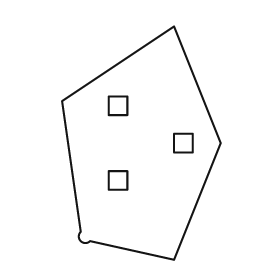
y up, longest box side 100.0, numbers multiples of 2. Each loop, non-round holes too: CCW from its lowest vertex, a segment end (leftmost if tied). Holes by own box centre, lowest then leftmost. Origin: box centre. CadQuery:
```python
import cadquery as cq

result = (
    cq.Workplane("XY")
    .moveTo(14.0, -50.0)
    .lineTo(34.0, 0.0)
    .lineTo(14.0, 50.0)
    .lineTo(-34.0, 18.0)
    .lineTo(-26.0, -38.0)
    .threePointArc((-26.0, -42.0), (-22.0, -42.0))
    .close()
    .moveTo(-14.0, -20.0)
    .lineTo(-6.0, -20.0)
    .lineTo(-6.0, -12.0)
    .lineTo(-14.0, -12.0)
    .close()
    .moveTo(14.0, -4.0)
    .lineTo(22.0, -4.0)
    .lineTo(22.0, 4.0)
    .lineTo(14.0, 4.0)
    .close()
    .moveTo(-14.0, 12.0)
    .lineTo(-6.0, 12.0)
    .lineTo(-6.0, 20.0)
    .lineTo(-14.0, 20.0)
    .close()
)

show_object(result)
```